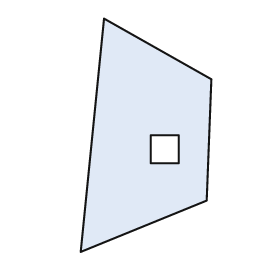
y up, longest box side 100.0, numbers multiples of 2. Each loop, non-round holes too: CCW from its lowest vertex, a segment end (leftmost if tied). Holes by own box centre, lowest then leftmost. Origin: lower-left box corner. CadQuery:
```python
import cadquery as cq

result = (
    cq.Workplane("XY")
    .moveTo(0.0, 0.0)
    .lineTo(54.0, 22.0)
    .lineTo(56.0, 74.0)
    .lineTo(10.0, 100.0)
    .close()
    .moveTo(30.0, 38.0)
    .lineTo(42.0, 38.0)
    .lineTo(42.0, 50.0)
    .lineTo(30.0, 50.0)
    .close()
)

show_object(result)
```